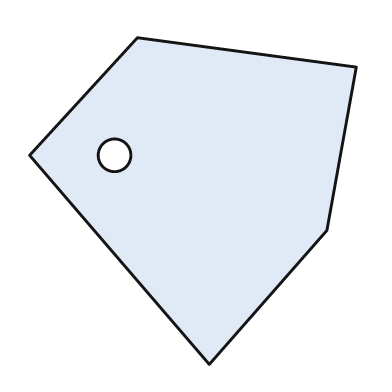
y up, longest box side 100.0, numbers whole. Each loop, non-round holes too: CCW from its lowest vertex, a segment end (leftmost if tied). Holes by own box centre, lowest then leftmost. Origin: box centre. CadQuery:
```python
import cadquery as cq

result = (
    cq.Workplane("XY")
    .moveTo(5.0, -50.0)
    .lineTo(41.0, -9.0)
    .lineTo(50.0, 41.0)
    .lineTo(-17.0, 50.0)
    .lineTo(-50.0, 14.0)
    .close()
    .moveTo(-24.0, 14.0)
    .circle(5.0)
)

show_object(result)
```